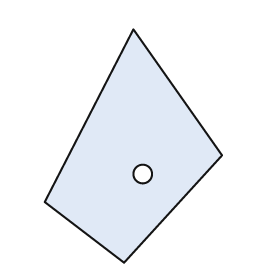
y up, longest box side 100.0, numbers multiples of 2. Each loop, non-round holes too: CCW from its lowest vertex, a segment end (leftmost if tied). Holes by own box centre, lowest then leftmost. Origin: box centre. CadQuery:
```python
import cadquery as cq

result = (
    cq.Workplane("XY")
    .moveTo(-4.0, -50.0)
    .lineTo(38.0, -4.0)
    .lineTo(0.0, 50.0)
    .lineTo(-38.0, -24.0)
    .close()
    .moveTo(4.0, -12.0)
    .circle(4.0)
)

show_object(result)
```